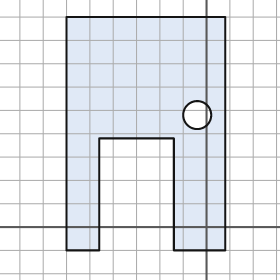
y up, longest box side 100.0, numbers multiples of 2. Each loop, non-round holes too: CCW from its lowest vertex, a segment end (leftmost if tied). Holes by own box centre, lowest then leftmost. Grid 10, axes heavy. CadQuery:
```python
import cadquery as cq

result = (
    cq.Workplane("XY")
    .moveTo(-60.0, -10.0)
    .lineTo(-46.0, -10.0)
    .lineTo(-46.0, 38.0)
    .lineTo(-14.0, 38.0)
    .lineTo(-14.0, -10.0)
    .lineTo(8.0, -10.0)
    .lineTo(8.0, 90.0)
    .lineTo(-60.0, 90.0)
    .close()
    .moveTo(-4.0, 48.0)
    .circle(6.0)
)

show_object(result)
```